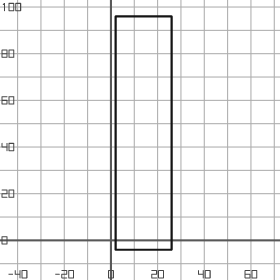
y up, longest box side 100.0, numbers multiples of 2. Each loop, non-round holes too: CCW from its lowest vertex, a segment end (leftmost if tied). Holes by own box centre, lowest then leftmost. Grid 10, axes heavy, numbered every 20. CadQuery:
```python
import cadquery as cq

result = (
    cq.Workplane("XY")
    .moveTo(2.0, -4.0)
    .lineTo(26.0, -4.0)
    .lineTo(26.0, 96.0)
    .lineTo(2.0, 96.0)
    .close()
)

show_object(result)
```